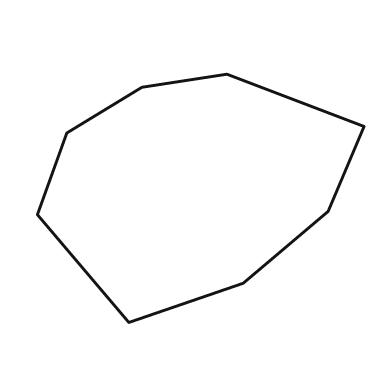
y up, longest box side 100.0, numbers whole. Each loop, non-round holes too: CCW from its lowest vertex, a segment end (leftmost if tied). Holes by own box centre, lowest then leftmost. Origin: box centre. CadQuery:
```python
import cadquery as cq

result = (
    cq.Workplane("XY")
    .moveTo(-22.0, -38.0)
    .lineTo(13.0, -26.0)
    .lineTo(39.0, -4.0)
    .lineTo(50.0, 22.0)
    .lineTo(8.0, 38.0)
    .lineTo(-18.0, 34.0)
    .lineTo(-41.0, 20.0)
    .lineTo(-50.0, -5.0)
    .close()
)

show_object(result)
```